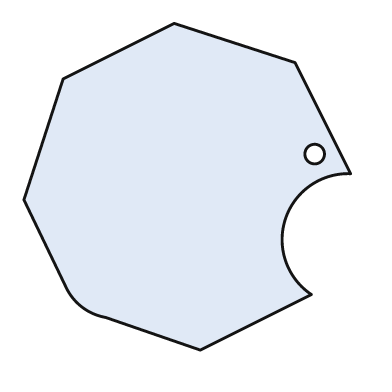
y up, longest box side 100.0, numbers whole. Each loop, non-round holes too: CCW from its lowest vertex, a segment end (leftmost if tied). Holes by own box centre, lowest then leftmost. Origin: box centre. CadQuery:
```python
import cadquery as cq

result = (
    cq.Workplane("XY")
    .moveTo(4.0, -50.0)
    .lineTo(38.0, -33.0)
    .threePointArc((30.0, -10.0), (50.0, 4.0))
    .lineTo(33.0, 38.0)
    .lineTo(-4.0, 50.0)
    .lineTo(-38.0, 33.0)
    .lineTo(-50.0, -4.0)
    .lineTo(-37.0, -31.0)
    .threePointArc((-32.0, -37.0), (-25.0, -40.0))
    .close()
    .moveTo(39.0, 10.0)
    .circle(3.0)
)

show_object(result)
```